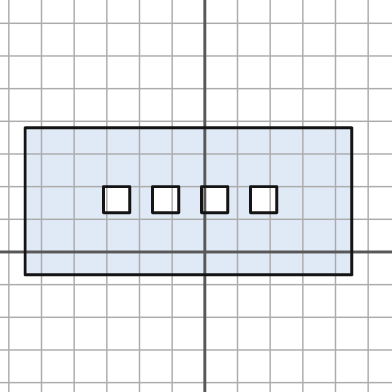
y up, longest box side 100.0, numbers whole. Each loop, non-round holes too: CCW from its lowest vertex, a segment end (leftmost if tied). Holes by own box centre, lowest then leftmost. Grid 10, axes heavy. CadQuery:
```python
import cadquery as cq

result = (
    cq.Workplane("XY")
    .moveTo(-55.0, -7.0)
    .lineTo(45.0, -7.0)
    .lineTo(45.0, 38.0)
    .lineTo(-55.0, 38.0)
    .close()
    .moveTo(-31.0, 12.0)
    .lineTo(-23.0, 12.0)
    .lineTo(-23.0, 20.0)
    .lineTo(-31.0, 20.0)
    .close()
    .moveTo(-16.0, 12.0)
    .lineTo(-8.0, 12.0)
    .lineTo(-8.0, 20.0)
    .lineTo(-16.0, 20.0)
    .close()
    .moveTo(-1.0, 12.0)
    .lineTo(7.0, 12.0)
    .lineTo(7.0, 20.0)
    .lineTo(-1.0, 20.0)
    .close()
    .moveTo(14.0, 12.0)
    .lineTo(22.0, 12.0)
    .lineTo(22.0, 20.0)
    .lineTo(14.0, 20.0)
    .close()
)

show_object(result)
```